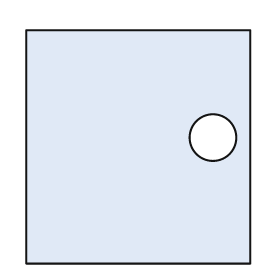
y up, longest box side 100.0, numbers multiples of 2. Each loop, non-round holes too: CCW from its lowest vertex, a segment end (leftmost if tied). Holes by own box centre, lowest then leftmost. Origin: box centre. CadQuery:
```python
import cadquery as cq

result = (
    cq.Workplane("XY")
    .moveTo(-48.0, -50.0)
    .lineTo(48.0, -50.0)
    .lineTo(48.0, 50.0)
    .lineTo(-48.0, 50.0)
    .close()
    .moveTo(32.0, 4.0)
    .circle(10.0)
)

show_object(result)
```